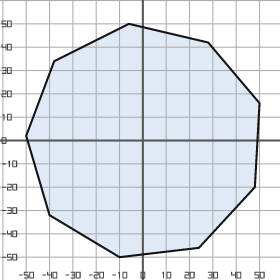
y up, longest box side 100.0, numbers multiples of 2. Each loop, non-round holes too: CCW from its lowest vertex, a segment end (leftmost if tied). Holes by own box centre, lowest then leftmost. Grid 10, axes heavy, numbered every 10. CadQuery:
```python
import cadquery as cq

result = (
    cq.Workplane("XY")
    .moveTo(-10.0, -50.0)
    .lineTo(24.0, -46.0)
    .lineTo(48.0, -20.0)
    .lineTo(50.0, 16.0)
    .lineTo(28.0, 42.0)
    .lineTo(-6.0, 50.0)
    .lineTo(-38.0, 34.0)
    .lineTo(-50.0, 2.0)
    .lineTo(-40.0, -32.0)
    .close()
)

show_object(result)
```